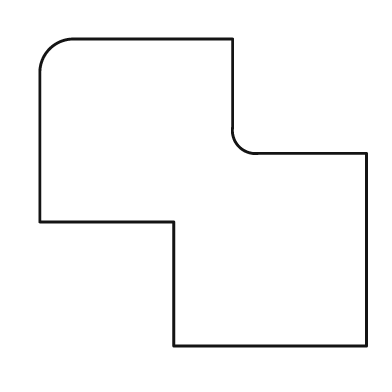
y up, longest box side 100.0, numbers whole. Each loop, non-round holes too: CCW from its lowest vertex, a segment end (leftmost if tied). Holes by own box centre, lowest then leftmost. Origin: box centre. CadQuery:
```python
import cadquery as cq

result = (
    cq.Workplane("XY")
    .moveTo(-9.0, -47.0)
    .lineTo(50.0, -47.0)
    .lineTo(50.0, 12.0)
    .lineTo(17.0, 12.0)
    .threePointArc((11.0, 14.0), (9.0, 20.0))
    .lineTo(9.0, 47.0)
    .lineTo(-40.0, 47.0)
    .threePointArc((-47.0, 44.0), (-50.0, 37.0))
    .lineTo(-50.0, -9.0)
    .lineTo(-9.0, -9.0)
    .close()
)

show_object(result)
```